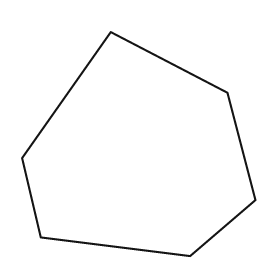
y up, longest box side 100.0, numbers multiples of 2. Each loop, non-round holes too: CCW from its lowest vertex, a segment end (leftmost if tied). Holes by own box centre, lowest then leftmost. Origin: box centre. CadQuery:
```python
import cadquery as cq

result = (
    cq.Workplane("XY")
    .moveTo(22.0, -48.0)
    .lineTo(50.0, -24.0)
    .lineTo(38.0, 22.0)
    .lineTo(-12.0, 48.0)
    .lineTo(-50.0, -6.0)
    .lineTo(-42.0, -40.0)
    .close()
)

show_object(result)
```